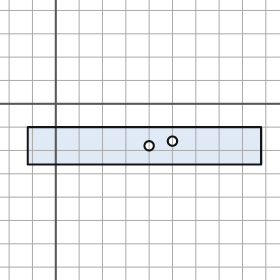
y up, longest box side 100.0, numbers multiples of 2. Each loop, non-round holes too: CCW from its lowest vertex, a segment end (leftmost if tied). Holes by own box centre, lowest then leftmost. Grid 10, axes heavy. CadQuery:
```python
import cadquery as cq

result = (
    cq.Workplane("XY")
    .moveTo(-12.0, -26.0)
    .lineTo(88.0, -26.0)
    .lineTo(88.0, -10.0)
    .lineTo(-12.0, -10.0)
    .close()
    .moveTo(40.0, -18.0)
    .circle(2.0)
    .moveTo(50.0, -16.0)
    .circle(2.0)
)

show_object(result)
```